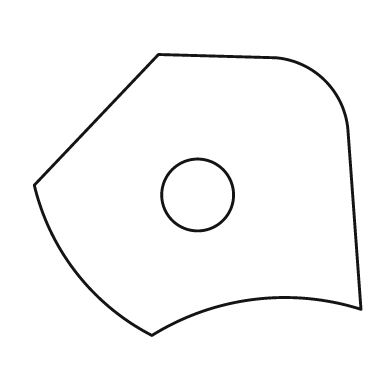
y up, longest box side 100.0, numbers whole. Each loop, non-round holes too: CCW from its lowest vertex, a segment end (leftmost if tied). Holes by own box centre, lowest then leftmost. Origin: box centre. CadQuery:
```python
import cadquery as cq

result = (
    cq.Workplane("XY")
    .moveTo(-14.0, -43.0)
    .threePointArc((17.0, -32.0), (50.0, -35.0))
    .lineTo(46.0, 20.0)
    .threePointArc((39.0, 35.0), (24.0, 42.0))
    .lineTo(-12.0, 43.0)
    .lineTo(-50.0, 3.0)
    .threePointArc((-37.0, -24.0), (-14.0, -43.0))
    .close()
    .moveTo(0.0, 0.0)
    .circle(11.0)
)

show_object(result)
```